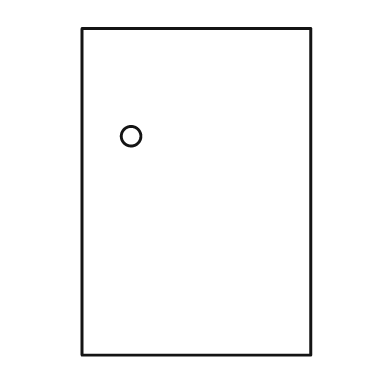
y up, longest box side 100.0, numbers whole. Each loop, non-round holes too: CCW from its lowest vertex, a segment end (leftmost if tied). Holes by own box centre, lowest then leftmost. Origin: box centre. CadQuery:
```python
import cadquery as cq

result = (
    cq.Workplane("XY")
    .moveTo(-35.0, -50.0)
    .lineTo(35.0, -50.0)
    .lineTo(35.0, 50.0)
    .lineTo(-35.0, 50.0)
    .close()
    .moveTo(-20.0, 17.0)
    .circle(3.0)
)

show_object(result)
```